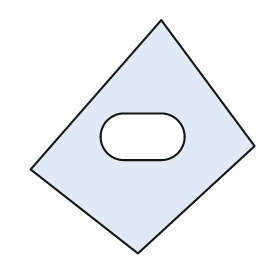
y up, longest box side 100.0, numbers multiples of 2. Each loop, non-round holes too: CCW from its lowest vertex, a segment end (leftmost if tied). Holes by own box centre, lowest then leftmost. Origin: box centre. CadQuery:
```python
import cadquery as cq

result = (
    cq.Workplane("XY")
    .moveTo(-2.0, -50.0)
    .lineTo(48.0, -4.0)
    .lineTo(8.0, 50.0)
    .lineTo(-48.0, -14.0)
    .close()
    .moveTo(-8.0, -10.0)
    .lineTo(8.0, -10.0)
    .threePointArc((18.0, 0.0), (8.0, 10.0))
    .lineTo(-8.0, 10.0)
    .threePointArc((-18.0, 0.0), (-8.0, -10.0))
    .close()
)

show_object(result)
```